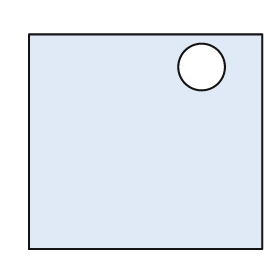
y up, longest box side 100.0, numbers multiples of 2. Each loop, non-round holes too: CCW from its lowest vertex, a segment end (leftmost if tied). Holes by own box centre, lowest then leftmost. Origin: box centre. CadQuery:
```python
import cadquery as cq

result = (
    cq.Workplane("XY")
    .moveTo(-50.0, -46.0)
    .lineTo(50.0, -46.0)
    .lineTo(50.0, 46.0)
    .lineTo(-50.0, 46.0)
    .close()
    .moveTo(24.0, 32.0)
    .circle(10.0)
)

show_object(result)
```